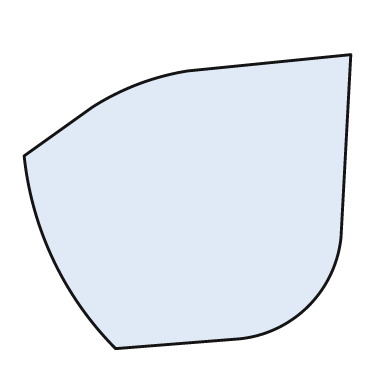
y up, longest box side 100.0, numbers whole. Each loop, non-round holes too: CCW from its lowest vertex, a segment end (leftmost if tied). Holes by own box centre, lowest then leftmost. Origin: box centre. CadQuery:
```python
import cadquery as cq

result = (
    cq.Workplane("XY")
    .moveTo(-22.0, -45.0)
    .lineTo(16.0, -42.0)
    .threePointArc((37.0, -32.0), (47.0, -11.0))
    .lineTo(50.0, 45.0)
    .lineTo(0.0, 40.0)
    .threePointArc((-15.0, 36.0), (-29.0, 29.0))
    .lineTo(-50.0, 14.0)
    .threePointArc((-41.0, -18.0), (-22.0, -45.0))
    .close()
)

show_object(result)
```